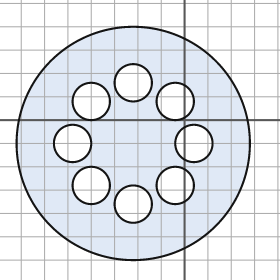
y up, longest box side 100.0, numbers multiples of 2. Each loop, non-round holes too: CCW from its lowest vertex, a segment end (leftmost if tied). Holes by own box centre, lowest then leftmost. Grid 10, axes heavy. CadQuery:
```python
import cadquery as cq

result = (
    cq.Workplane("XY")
    .moveTo(-22.0, -10.0)
    .circle(50.0)
    .moveTo(-22.0, -36.0)
    .circle(8.0)
    .moveTo(-40.0, -28.0)
    .circle(8.0)
    .moveTo(-4.0, -28.0)
    .circle(8.0)
    .moveTo(-48.0, -10.0)
    .circle(8.0)
    .moveTo(4.0, -10.0)
    .circle(8.0)
    .moveTo(-40.0, 8.0)
    .circle(8.0)
    .moveTo(-4.0, 8.0)
    .circle(8.0)
    .moveTo(-22.0, 16.0)
    .circle(8.0)
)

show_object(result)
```